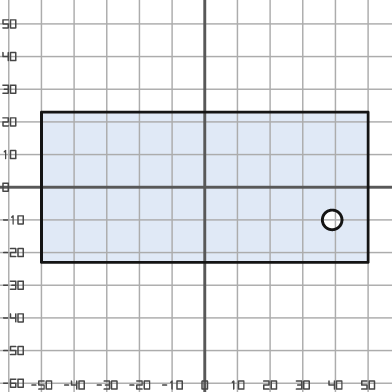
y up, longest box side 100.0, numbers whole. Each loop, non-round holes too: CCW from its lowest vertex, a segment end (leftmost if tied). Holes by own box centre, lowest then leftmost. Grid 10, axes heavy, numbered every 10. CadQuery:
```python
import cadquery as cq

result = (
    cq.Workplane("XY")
    .moveTo(-50.0, -23.0)
    .lineTo(50.0, -23.0)
    .lineTo(50.0, 23.0)
    .lineTo(-50.0, 23.0)
    .close()
    .moveTo(39.0, -10.0)
    .circle(3.0)
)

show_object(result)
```